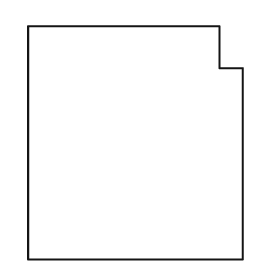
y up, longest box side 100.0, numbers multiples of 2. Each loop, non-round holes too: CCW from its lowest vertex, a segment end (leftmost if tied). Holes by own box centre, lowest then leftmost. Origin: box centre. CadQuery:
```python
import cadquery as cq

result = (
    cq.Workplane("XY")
    .moveTo(-46.0, -50.0)
    .lineTo(46.0, -50.0)
    .lineTo(46.0, 32.0)
    .lineTo(36.0, 32.0)
    .lineTo(36.0, 50.0)
    .lineTo(-46.0, 50.0)
    .close()
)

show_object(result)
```